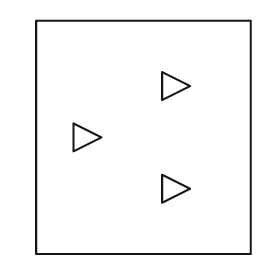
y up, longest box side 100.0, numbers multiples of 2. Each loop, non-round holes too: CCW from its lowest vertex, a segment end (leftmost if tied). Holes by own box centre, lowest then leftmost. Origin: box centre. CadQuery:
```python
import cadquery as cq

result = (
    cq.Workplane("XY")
    .moveTo(-46.0, -50.0)
    .lineTo(46.0, -50.0)
    .lineTo(46.0, 50.0)
    .lineTo(-46.0, 50.0)
    .close()
    .moveTo(8.0, -28.0)
    .lineTo(20.0, -22.0)
    .lineTo(8.0, -16.0)
    .close()
    .moveTo(-30.0, -6.0)
    .lineTo(-18.0, 0.0)
    .lineTo(-30.0, 6.0)
    .close()
    .moveTo(8.0, 16.0)
    .lineTo(20.0, 22.0)
    .lineTo(8.0, 28.0)
    .close()
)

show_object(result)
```